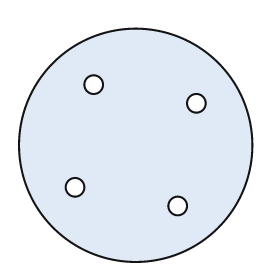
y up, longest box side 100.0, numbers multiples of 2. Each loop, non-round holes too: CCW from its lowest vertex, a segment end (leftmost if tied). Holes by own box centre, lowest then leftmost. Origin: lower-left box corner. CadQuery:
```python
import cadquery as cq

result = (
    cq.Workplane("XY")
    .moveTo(50.0, 50.0)
    .circle(50.0)
    .moveTo(68.0, 24.0)
    .circle(4.0)
    .moveTo(24.0, 32.0)
    .circle(4.0)
    .moveTo(76.0, 68.0)
    .circle(4.0)
    .moveTo(32.0, 76.0)
    .circle(4.0)
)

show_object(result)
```